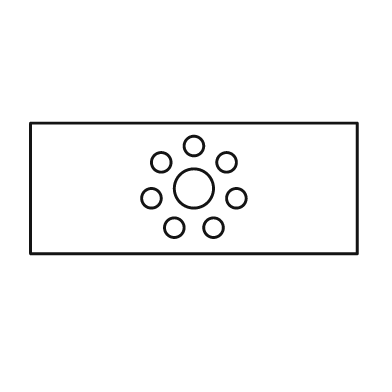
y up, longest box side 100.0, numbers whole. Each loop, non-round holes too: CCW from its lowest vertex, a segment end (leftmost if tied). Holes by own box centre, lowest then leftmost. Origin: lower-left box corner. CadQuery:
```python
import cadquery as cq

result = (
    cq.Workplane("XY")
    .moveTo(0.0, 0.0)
    .lineTo(100.0, 0.0)
    .lineTo(100.0, 40.0)
    .lineTo(0.0, 40.0)
    .close()
    .moveTo(44.0, 8.0)
    .circle(3.0)
    .moveTo(56.0, 8.0)
    .circle(3.0)
    .moveTo(37.0, 17.0)
    .circle(3.0)
    .moveTo(63.0, 17.0)
    .circle(3.0)
    .moveTo(50.0, 20.0)
    .circle(6.0)
    .moveTo(40.0, 28.0)
    .circle(3.0)
    .moveTo(60.0, 28.0)
    .circle(3.0)
    .moveTo(50.0, 33.0)
    .circle(3.0)
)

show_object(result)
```